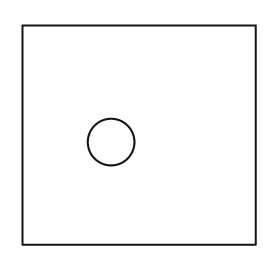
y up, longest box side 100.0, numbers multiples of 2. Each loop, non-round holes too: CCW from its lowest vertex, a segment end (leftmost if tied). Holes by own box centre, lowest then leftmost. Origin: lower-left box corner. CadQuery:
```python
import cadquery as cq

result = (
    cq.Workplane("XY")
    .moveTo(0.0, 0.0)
    .lineTo(100.0, 0.0)
    .lineTo(100.0, 94.0)
    .lineTo(0.0, 94.0)
    .close()
    .moveTo(38.0, 44.0)
    .circle(10.0)
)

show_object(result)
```